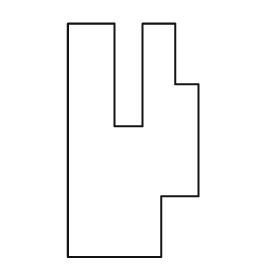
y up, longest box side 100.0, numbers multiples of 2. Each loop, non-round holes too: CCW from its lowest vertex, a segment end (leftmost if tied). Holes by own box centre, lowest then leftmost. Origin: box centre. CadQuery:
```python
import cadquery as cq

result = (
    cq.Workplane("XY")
    .moveTo(-28.0, -50.0)
    .lineTo(12.0, -50.0)
    .lineTo(12.0, -24.0)
    .lineTo(28.0, -24.0)
    .lineTo(28.0, 24.0)
    .lineTo(18.0, 24.0)
    .lineTo(18.0, 50.0)
    .lineTo(4.0, 50.0)
    .lineTo(4.0, 6.0)
    .lineTo(-8.0, 6.0)
    .lineTo(-8.0, 50.0)
    .lineTo(-28.0, 50.0)
    .close()
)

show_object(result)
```